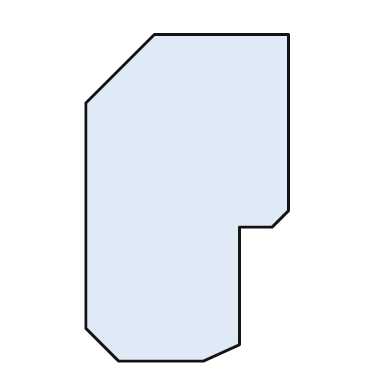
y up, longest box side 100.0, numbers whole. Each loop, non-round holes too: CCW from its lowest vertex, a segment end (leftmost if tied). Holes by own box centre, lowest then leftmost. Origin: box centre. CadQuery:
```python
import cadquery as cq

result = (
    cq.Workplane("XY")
    .moveTo(-21.0, -50.0)
    .lineTo(5.0, -50.0)
    .lineTo(16.0, -45.0)
    .lineTo(16.0, -9.0)
    .lineTo(26.0, -9.0)
    .lineTo(31.0, -4.0)
    .lineTo(31.0, 50.0)
    .lineTo(-10.0, 50.0)
    .lineTo(-31.0, 29.0)
    .lineTo(-31.0, -40.0)
    .close()
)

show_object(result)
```